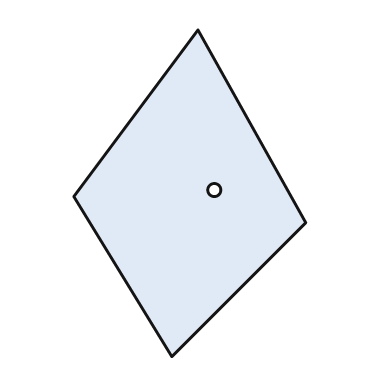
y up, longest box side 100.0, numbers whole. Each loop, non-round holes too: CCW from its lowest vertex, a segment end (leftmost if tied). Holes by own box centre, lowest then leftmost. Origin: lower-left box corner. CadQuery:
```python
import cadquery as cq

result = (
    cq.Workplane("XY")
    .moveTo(30.0, 0.0)
    .lineTo(71.0, 41.0)
    .lineTo(38.0, 100.0)
    .lineTo(0.0, 49.0)
    .close()
    .moveTo(43.0, 51.0)
    .circle(2.0)
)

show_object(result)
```